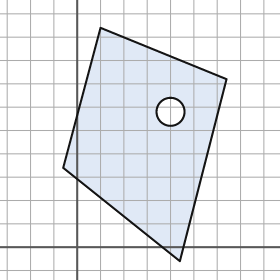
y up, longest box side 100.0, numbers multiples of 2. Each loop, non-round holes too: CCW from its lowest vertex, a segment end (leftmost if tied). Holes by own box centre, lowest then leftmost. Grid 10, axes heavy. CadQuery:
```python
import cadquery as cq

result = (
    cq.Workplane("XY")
    .moveTo(44.0, -6.0)
    .lineTo(64.0, 72.0)
    .lineTo(10.0, 94.0)
    .lineTo(-6.0, 34.0)
    .close()
    .moveTo(40.0, 58.0)
    .circle(6.0)
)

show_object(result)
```